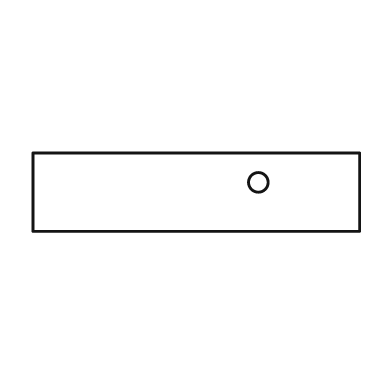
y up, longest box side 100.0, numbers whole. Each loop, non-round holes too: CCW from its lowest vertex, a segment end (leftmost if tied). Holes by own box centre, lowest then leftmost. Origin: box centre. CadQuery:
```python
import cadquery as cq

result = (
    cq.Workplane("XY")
    .moveTo(-50.0, -12.0)
    .lineTo(50.0, -12.0)
    .lineTo(50.0, 12.0)
    .lineTo(-50.0, 12.0)
    .close()
    .moveTo(19.0, 3.0)
    .circle(3.0)
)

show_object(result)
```